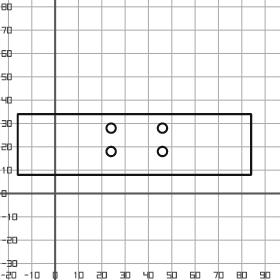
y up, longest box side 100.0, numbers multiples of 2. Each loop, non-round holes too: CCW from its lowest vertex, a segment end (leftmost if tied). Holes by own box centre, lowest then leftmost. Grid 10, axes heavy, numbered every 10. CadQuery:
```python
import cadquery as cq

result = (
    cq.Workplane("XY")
    .moveTo(-16.0, 8.0)
    .lineTo(84.0, 8.0)
    .lineTo(84.0, 34.0)
    .lineTo(-16.0, 34.0)
    .close()
    .moveTo(24.0, 18.0)
    .circle(2.0)
    .moveTo(46.0, 18.0)
    .circle(2.0)
    .moveTo(24.0, 28.0)
    .circle(2.0)
    .moveTo(46.0, 28.0)
    .circle(2.0)
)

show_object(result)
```